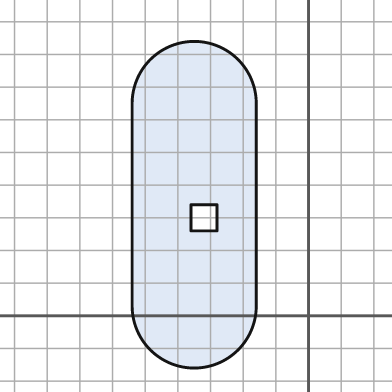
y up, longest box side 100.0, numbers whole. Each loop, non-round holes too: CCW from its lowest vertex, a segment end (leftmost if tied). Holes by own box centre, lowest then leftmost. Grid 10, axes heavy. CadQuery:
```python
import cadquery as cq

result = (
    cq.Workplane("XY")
    .moveTo(-54.0, 3.0)
    .threePointArc((-35.0, -16.0), (-16.0, 3.0))
    .lineTo(-16.0, 65.0)
    .threePointArc((-35.0, 84.0), (-54.0, 65.0))
    .close()
    .moveTo(-36.0, 26.0)
    .lineTo(-28.0, 26.0)
    .lineTo(-28.0, 34.0)
    .lineTo(-36.0, 34.0)
    .close()
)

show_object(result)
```